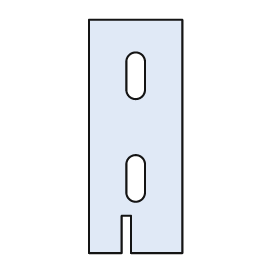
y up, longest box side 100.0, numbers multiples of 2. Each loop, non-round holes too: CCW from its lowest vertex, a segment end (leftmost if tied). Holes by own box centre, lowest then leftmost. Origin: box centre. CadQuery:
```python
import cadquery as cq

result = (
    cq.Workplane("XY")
    .moveTo(-20.0, -50.0)
    .lineTo(-6.0, -50.0)
    .lineTo(-6.0, -34.0)
    .lineTo(-2.0, -34.0)
    .lineTo(-2.0, -50.0)
    .lineTo(20.0, -50.0)
    .lineTo(20.0, 50.0)
    .lineTo(-20.0, 50.0)
    .close()
    .moveTo(-4.0, -24.0)
    .threePointArc((0.0, -28.0), (4.0, -24.0))
    .lineTo(4.0, -12.0)
    .threePointArc((0.0, -8.0), (-4.0, -12.0))
    .close()
    .moveTo(-4.0, 20.0)
    .threePointArc((0.0, 16.0), (4.0, 20.0))
    .lineTo(4.0, 32.0)
    .threePointArc((0.0, 36.0), (-4.0, 32.0))
    .close()
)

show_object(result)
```